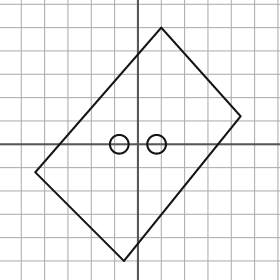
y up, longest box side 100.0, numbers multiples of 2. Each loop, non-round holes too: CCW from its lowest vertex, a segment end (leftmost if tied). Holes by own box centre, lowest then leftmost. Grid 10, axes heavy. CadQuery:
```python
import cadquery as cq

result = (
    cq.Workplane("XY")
    .moveTo(-6.0, -50.0)
    .lineTo(44.0, 12.0)
    .lineTo(10.0, 50.0)
    .lineTo(-44.0, -12.0)
    .close()
    .moveTo(-8.0, 0.0)
    .circle(4.0)
    .moveTo(8.0, 0.0)
    .circle(4.0)
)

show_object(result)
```